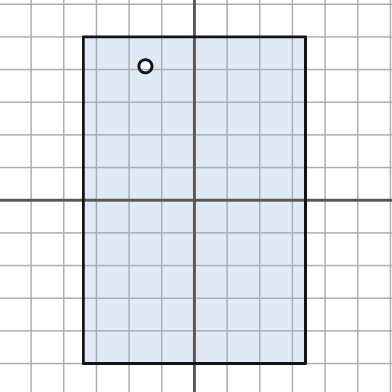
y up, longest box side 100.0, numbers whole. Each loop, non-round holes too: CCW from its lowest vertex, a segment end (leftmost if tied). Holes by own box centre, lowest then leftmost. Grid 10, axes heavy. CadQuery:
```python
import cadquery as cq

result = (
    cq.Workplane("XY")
    .moveTo(-34.0, -50.0)
    .lineTo(34.0, -50.0)
    .lineTo(34.0, 50.0)
    .lineTo(-34.0, 50.0)
    .close()
    .moveTo(-15.0, 41.0)
    .circle(2.0)
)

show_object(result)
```